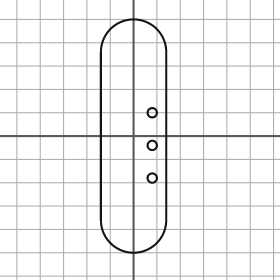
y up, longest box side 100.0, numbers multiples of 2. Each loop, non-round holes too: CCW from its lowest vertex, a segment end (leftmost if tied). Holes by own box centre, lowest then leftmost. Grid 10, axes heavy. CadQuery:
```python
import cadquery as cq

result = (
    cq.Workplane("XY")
    .moveTo(-14.0, -36.0)
    .threePointArc((0.0, -50.0), (14.0, -36.0))
    .lineTo(14.0, 36.0)
    .threePointArc((0.0, 50.0), (-14.0, 36.0))
    .close()
    .moveTo(8.0, -18.0)
    .circle(2.0)
    .moveTo(8.0, -4.0)
    .circle(2.0)
    .moveTo(8.0, 10.0)
    .circle(2.0)
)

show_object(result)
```